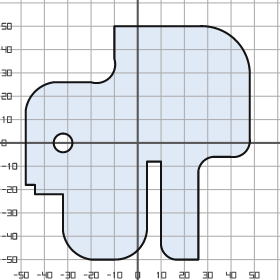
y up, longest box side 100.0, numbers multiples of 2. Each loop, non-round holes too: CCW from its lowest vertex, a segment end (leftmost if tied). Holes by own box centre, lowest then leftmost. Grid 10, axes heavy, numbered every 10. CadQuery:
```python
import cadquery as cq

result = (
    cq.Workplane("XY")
    .moveTo(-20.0, -50.0)
    .lineTo(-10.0, -50.0)
    .threePointArc((0.0, -46.0), (4.0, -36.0))
    .lineTo(4.0, -8.0)
    .lineTo(10.0, -8.0)
    .lineTo(10.0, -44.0)
    .threePointArc((12.0, -48.0), (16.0, -50.0))
    .lineTo(26.0, -50.0)
    .lineTo(26.0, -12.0)
    .threePointArc((28.0, -8.0), (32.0, -6.0))
    .lineTo(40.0, -6.0)
    .threePointArc((46.0, -4.0), (48.0, 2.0))
    .lineTo(48.0, 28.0)
    .threePointArc((42.0, 44.0), (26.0, 50.0))
    .lineTo(-10.0, 50.0)
    .lineTo(-10.0, 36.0)
    .threePointArc((-12.0, 28.0), (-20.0, 26.0))
    .lineTo(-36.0, 26.0)
    .threePointArc((-44.0, 22.0), (-48.0, 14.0))
    .lineTo(-48.0, -18.0)
    .lineTo(-44.0, -18.0)
    .lineTo(-44.0, -22.0)
    .lineTo(-32.0, -22.0)
    .lineTo(-32.0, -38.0)
    .threePointArc((-28.0, -46.0), (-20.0, -50.0))
    .close()
    .moveTo(-32.0, 0.0)
    .circle(4.0)
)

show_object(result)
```